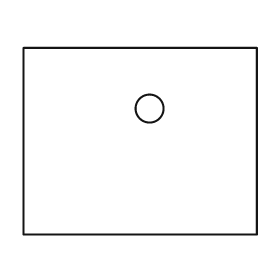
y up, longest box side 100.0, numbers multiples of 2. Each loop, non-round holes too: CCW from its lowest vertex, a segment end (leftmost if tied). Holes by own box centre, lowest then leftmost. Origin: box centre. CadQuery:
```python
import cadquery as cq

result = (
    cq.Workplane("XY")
    .moveTo(-50.0, -40.0)
    .lineTo(50.0, -40.0)
    .lineTo(50.0, 40.0)
    .lineTo(-50.0, 40.0)
    .close()
    .moveTo(4.0, 14.0)
    .circle(6.0)
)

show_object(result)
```